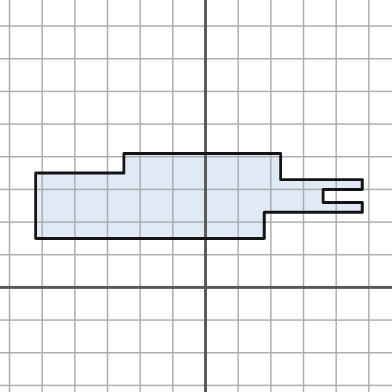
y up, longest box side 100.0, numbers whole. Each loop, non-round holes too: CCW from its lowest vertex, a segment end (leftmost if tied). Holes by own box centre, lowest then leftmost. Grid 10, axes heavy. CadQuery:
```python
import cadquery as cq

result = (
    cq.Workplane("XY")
    .moveTo(-52.0, 15.0)
    .lineTo(18.0, 15.0)
    .lineTo(18.0, 23.0)
    .lineTo(48.0, 23.0)
    .lineTo(48.0, 26.0)
    .lineTo(36.0, 26.0)
    .lineTo(36.0, 30.0)
    .lineTo(48.0, 30.0)
    .lineTo(48.0, 33.0)
    .lineTo(23.0, 33.0)
    .lineTo(23.0, 41.0)
    .lineTo(-25.0, 41.0)
    .lineTo(-25.0, 35.0)
    .lineTo(-52.0, 35.0)
    .close()
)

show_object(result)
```